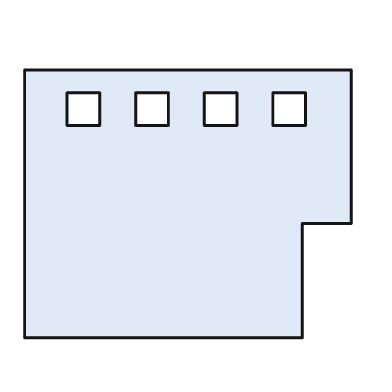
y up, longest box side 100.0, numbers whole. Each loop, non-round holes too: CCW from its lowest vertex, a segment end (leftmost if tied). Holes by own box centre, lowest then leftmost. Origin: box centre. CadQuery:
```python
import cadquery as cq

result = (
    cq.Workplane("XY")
    .moveTo(-50.0, -41.0)
    .lineTo(35.0, -41.0)
    .lineTo(35.0, -6.0)
    .lineTo(50.0, -6.0)
    .lineTo(50.0, 41.0)
    .lineTo(-50.0, 41.0)
    .close()
    .moveTo(-37.0, 24.0)
    .lineTo(-27.0, 24.0)
    .lineTo(-27.0, 34.0)
    .lineTo(-37.0, 34.0)
    .close()
    .moveTo(-16.0, 24.0)
    .lineTo(-6.0, 24.0)
    .lineTo(-6.0, 34.0)
    .lineTo(-16.0, 34.0)
    .close()
    .moveTo(5.0, 24.0)
    .lineTo(15.0, 24.0)
    .lineTo(15.0, 34.0)
    .lineTo(5.0, 34.0)
    .close()
    .moveTo(26.0, 24.0)
    .lineTo(36.0, 24.0)
    .lineTo(36.0, 34.0)
    .lineTo(26.0, 34.0)
    .close()
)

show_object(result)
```